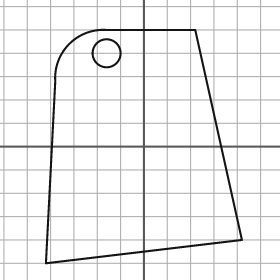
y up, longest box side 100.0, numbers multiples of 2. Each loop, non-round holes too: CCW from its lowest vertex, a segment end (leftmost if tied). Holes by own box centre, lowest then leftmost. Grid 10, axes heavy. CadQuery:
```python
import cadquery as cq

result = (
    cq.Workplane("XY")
    .moveTo(-42.0, -50.0)
    .lineTo(42.0, -40.0)
    .lineTo(22.0, 50.0)
    .lineTo(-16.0, 50.0)
    .threePointArc((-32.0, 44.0), (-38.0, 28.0))
    .close()
    .moveTo(-16.0, 40.0)
    .circle(6.0)
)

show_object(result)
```